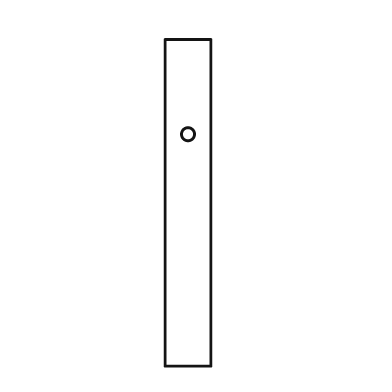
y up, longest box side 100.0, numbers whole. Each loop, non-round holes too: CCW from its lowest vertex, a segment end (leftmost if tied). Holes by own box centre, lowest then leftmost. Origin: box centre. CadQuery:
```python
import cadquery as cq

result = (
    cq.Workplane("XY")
    .moveTo(-7.0, -50.0)
    .lineTo(7.0, -50.0)
    .lineTo(7.0, 50.0)
    .lineTo(-7.0, 50.0)
    .close()
    .moveTo(0.0, 21.0)
    .circle(2.0)
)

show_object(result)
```